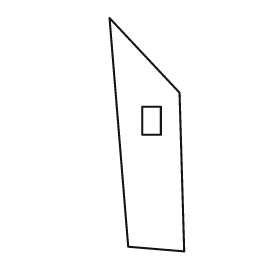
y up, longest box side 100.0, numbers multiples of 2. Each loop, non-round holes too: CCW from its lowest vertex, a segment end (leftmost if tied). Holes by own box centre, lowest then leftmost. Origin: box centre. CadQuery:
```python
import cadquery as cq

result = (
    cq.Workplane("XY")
    .moveTo(16.0, -50.0)
    .lineTo(14.0, 18.0)
    .lineTo(-16.0, 50.0)
    .lineTo(-8.0, -48.0)
    .close()
    .moveTo(-2.0, 0.0)
    .lineTo(6.0, 0.0)
    .lineTo(6.0, 12.0)
    .lineTo(-2.0, 12.0)
    .close()
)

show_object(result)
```